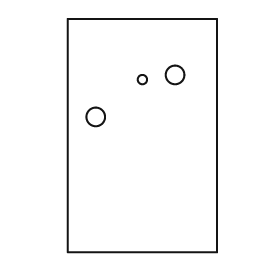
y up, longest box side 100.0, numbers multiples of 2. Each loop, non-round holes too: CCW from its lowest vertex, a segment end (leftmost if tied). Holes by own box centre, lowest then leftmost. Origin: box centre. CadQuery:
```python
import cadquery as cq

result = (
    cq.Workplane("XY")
    .moveTo(-32.0, -50.0)
    .lineTo(32.0, -50.0)
    .lineTo(32.0, 50.0)
    .lineTo(-32.0, 50.0)
    .close()
    .moveTo(-20.0, 8.0)
    .circle(4.0)
    .moveTo(0.0, 24.0)
    .circle(2.0)
    .moveTo(14.0, 26.0)
    .circle(4.0)
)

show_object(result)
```